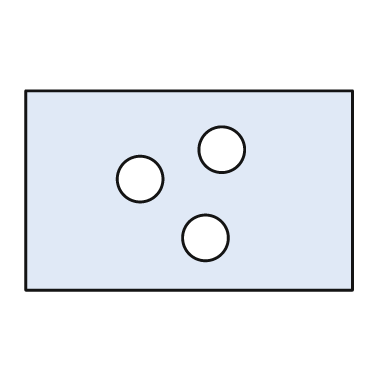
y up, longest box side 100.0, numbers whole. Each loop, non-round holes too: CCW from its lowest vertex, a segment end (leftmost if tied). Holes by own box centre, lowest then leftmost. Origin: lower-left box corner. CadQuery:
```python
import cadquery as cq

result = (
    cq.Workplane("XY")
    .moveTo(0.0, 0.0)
    .lineTo(100.0, 0.0)
    .lineTo(100.0, 61.0)
    .lineTo(0.0, 61.0)
    .close()
    .moveTo(55.0, 16.0)
    .circle(7.0)
    .moveTo(35.0, 34.0)
    .circle(7.0)
    .moveTo(60.0, 43.0)
    .circle(7.0)
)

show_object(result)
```